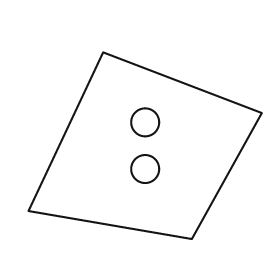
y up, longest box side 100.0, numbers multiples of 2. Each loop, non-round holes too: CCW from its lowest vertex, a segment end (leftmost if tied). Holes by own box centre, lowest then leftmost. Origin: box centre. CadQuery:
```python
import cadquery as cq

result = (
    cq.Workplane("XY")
    .moveTo(20.0, -40.0)
    .lineTo(50.0, 14.0)
    .lineTo(-18.0, 40.0)
    .lineTo(-50.0, -28.0)
    .close()
    .moveTo(0.0, -10.0)
    .circle(6.0)
    .moveTo(0.0, 10.0)
    .circle(6.0)
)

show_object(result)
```